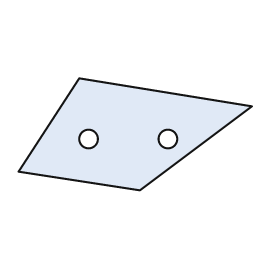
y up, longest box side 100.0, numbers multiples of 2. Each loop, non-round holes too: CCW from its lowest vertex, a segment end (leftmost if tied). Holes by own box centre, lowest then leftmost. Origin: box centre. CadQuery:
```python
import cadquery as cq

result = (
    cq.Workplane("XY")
    .moveTo(2.0, -24.0)
    .lineTo(50.0, 12.0)
    .lineTo(-24.0, 24.0)
    .lineTo(-50.0, -16.0)
    .close()
    .moveTo(-20.0, -2.0)
    .circle(4.0)
    .moveTo(14.0, -2.0)
    .circle(4.0)
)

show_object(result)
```